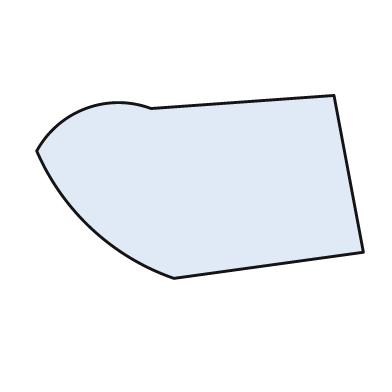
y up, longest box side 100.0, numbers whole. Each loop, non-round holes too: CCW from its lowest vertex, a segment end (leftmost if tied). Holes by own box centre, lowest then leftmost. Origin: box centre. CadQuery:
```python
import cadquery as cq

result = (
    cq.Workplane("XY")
    .moveTo(-8.0, -28.0)
    .lineTo(50.0, -20.0)
    .lineTo(41.0, 28.0)
    .lineTo(-15.0, 24.0)
    .threePointArc((-35.0, 24.0), (-50.0, 11.0))
    .threePointArc((-33.0, -13.0), (-8.0, -28.0))
    .close()
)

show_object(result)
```